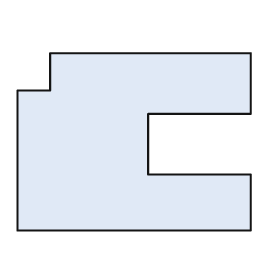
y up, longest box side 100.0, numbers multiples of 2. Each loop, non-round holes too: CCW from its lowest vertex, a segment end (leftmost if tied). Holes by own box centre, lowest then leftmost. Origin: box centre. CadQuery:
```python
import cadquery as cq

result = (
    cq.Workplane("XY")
    .moveTo(-50.0, -38.0)
    .lineTo(50.0, -38.0)
    .lineTo(50.0, -14.0)
    .lineTo(6.0, -14.0)
    .lineTo(6.0, 12.0)
    .lineTo(50.0, 12.0)
    .lineTo(50.0, 38.0)
    .lineTo(-36.0, 38.0)
    .lineTo(-36.0, 22.0)
    .lineTo(-50.0, 22.0)
    .close()
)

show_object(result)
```